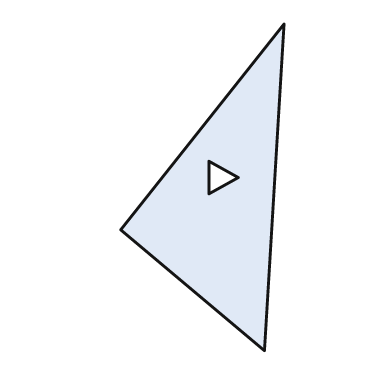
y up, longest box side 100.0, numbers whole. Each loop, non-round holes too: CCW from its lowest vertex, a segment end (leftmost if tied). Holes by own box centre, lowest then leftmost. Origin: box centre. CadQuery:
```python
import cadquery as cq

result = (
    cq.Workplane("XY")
    .moveTo(19.0, -50.0)
    .lineTo(25.0, 50.0)
    .lineTo(-25.0, -13.0)
    .close()
    .moveTo(2.0, -2.0)
    .lineTo(11.0, 3.0)
    .lineTo(2.0, 8.0)
    .close()
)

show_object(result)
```